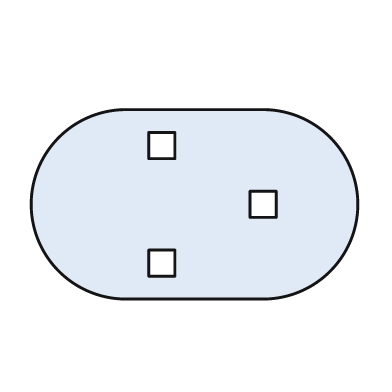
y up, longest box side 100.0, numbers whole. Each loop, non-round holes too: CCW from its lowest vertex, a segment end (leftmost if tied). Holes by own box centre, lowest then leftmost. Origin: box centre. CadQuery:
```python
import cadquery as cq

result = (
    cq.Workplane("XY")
    .moveTo(-21.0, -29.0)
    .lineTo(21.0, -29.0)
    .threePointArc((50.0, 0.0), (21.0, 29.0))
    .lineTo(-21.0, 29.0)
    .threePointArc((-50.0, 0.0), (-21.0, -29.0))
    .close()
    .moveTo(-14.0, -22.0)
    .lineTo(-6.0, -22.0)
    .lineTo(-6.0, -14.0)
    .lineTo(-14.0, -14.0)
    .close()
    .moveTo(17.0, -4.0)
    .lineTo(25.0, -4.0)
    .lineTo(25.0, 4.0)
    .lineTo(17.0, 4.0)
    .close()
    .moveTo(-14.0, 14.0)
    .lineTo(-6.0, 14.0)
    .lineTo(-6.0, 22.0)
    .lineTo(-14.0, 22.0)
    .close()
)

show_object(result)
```